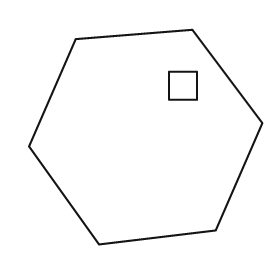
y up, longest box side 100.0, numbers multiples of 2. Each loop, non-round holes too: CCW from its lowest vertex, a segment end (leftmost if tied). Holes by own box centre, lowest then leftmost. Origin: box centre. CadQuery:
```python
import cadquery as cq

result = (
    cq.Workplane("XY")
    .moveTo(-20.0, -46.0)
    .lineTo(30.0, -40.0)
    .lineTo(50.0, 6.0)
    .lineTo(20.0, 46.0)
    .lineTo(-30.0, 42.0)
    .lineTo(-50.0, -4.0)
    .close()
    .moveTo(10.0, 16.0)
    .lineTo(22.0, 16.0)
    .lineTo(22.0, 28.0)
    .lineTo(10.0, 28.0)
    .close()
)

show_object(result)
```